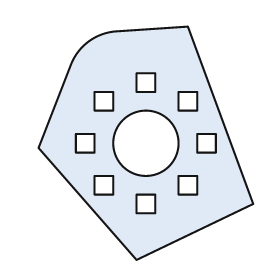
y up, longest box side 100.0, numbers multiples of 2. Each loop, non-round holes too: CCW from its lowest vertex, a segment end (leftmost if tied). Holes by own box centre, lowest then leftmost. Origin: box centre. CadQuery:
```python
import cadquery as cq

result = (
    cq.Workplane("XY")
    .moveTo(-4.0, -50.0)
    .lineTo(46.0, -26.0)
    .lineTo(18.0, 50.0)
    .lineTo(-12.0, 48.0)
    .threePointArc((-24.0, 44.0), (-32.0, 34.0))
    .lineTo(-46.0, -2.0)
    .close()
    .moveTo(-4.0, -30.0)
    .lineTo(4.0, -30.0)
    .lineTo(4.0, -22.0)
    .lineTo(-4.0, -22.0)
    .close()
    .moveTo(-22.0, -22.0)
    .lineTo(-14.0, -22.0)
    .lineTo(-14.0, -14.0)
    .lineTo(-22.0, -14.0)
    .close()
    .moveTo(14.0, -22.0)
    .lineTo(22.0, -22.0)
    .lineTo(22.0, -14.0)
    .lineTo(14.0, -14.0)
    .close()
    .moveTo(-30.0, -4.0)
    .lineTo(-22.0, -4.0)
    .lineTo(-22.0, 4.0)
    .lineTo(-30.0, 4.0)
    .close()
    .moveTo(0.0, 0.0)
    .circle(14.0)
    .moveTo(22.0, -4.0)
    .lineTo(30.0, -4.0)
    .lineTo(30.0, 4.0)
    .lineTo(22.0, 4.0)
    .close()
    .moveTo(-22.0, 14.0)
    .lineTo(-14.0, 14.0)
    .lineTo(-14.0, 22.0)
    .lineTo(-22.0, 22.0)
    .close()
    .moveTo(14.0, 14.0)
    .lineTo(22.0, 14.0)
    .lineTo(22.0, 22.0)
    .lineTo(14.0, 22.0)
    .close()
    .moveTo(-4.0, 22.0)
    .lineTo(4.0, 22.0)
    .lineTo(4.0, 30.0)
    .lineTo(-4.0, 30.0)
    .close()
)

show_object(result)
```